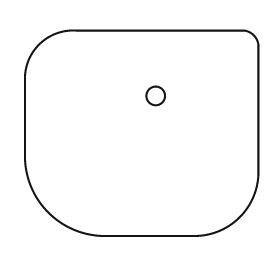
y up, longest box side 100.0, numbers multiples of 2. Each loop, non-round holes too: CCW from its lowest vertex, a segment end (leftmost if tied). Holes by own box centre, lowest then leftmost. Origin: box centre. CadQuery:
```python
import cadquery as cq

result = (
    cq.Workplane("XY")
    .moveTo(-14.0, -44.0)
    .lineTo(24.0, -44.0)
    .threePointArc((42.0, -36.0), (50.0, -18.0))
    .lineTo(50.0, 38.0)
    .threePointArc((48.0, 42.0), (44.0, 44.0))
    .lineTo(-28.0, 44.0)
    .threePointArc((-44.0, 38.0), (-50.0, 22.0))
    .lineTo(-50.0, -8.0)
    .threePointArc((-40.0, -34.0), (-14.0, -44.0))
    .close()
    .moveTo(6.0, 16.0)
    .circle(4.0)
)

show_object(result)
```